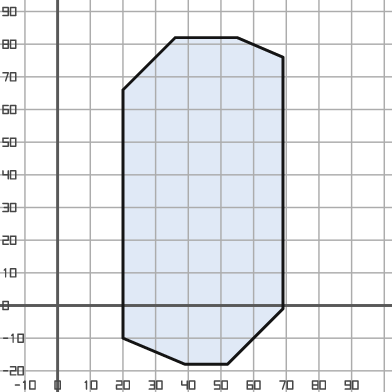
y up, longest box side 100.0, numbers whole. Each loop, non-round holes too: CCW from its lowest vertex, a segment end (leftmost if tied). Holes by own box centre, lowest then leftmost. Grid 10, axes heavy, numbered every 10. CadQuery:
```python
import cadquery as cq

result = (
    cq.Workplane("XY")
    .moveTo(39.0, -18.0)
    .lineTo(52.0, -18.0)
    .lineTo(69.0, -1.0)
    .lineTo(69.0, 76.0)
    .lineTo(55.0, 82.0)
    .lineTo(36.0, 82.0)
    .lineTo(20.0, 66.0)
    .lineTo(20.0, -10.0)
    .close()
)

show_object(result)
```